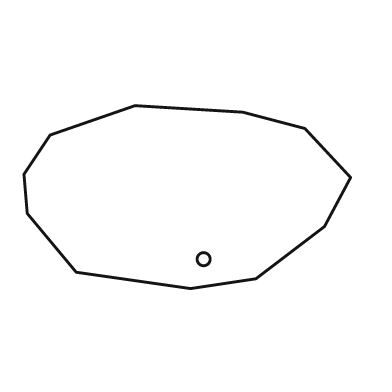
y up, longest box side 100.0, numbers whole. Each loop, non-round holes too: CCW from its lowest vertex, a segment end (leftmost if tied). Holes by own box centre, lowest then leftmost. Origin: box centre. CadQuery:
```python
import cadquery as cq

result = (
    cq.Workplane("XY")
    .moveTo(1.0, -28.0)
    .lineTo(21.0, -25.0)
    .lineTo(42.0, -9.0)
    .lineTo(50.0, 6.0)
    .lineTo(36.0, 21.0)
    .lineTo(17.0, 26.0)
    .lineTo(-16.0, 28.0)
    .lineTo(-42.0, 19.0)
    .lineTo(-50.0, 7.0)
    .lineTo(-49.0, -5.0)
    .lineTo(-34.0, -23.0)
    .close()
    .moveTo(5.0, -19.0)
    .circle(2.0)
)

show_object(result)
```